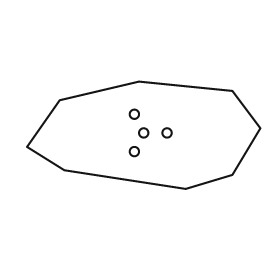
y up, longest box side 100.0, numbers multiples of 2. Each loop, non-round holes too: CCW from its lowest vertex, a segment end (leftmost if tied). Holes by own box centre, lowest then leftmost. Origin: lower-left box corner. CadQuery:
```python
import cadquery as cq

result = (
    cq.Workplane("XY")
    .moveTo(68.0, 0.0)
    .lineTo(88.0, 6.0)
    .lineTo(100.0, 26.0)
    .lineTo(88.0, 42.0)
    .lineTo(48.0, 46.0)
    .lineTo(14.0, 38.0)
    .lineTo(0.0, 18.0)
    .lineTo(16.0, 8.0)
    .close()
    .moveTo(46.0, 16.0)
    .circle(2.0)
    .moveTo(50.0, 24.0)
    .circle(2.0)
    .moveTo(60.0, 24.0)
    .circle(2.0)
    .moveTo(46.0, 32.0)
    .circle(2.0)
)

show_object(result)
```